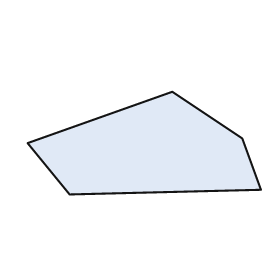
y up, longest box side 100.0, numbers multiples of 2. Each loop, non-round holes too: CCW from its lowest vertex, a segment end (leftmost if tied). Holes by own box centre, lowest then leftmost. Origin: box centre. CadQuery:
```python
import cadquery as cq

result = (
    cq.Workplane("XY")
    .moveTo(-32.0, -22.0)
    .lineTo(50.0, -20.0)
    .lineTo(42.0, 2.0)
    .lineTo(12.0, 22.0)
    .lineTo(-50.0, 0.0)
    .close()
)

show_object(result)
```